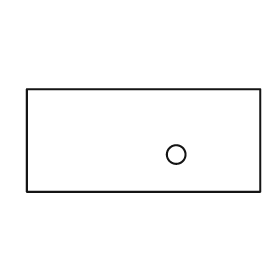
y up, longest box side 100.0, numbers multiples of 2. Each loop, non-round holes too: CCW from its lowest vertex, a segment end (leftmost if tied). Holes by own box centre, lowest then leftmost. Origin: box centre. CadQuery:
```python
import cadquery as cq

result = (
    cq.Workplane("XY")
    .moveTo(-50.0, -22.0)
    .lineTo(50.0, -22.0)
    .lineTo(50.0, 22.0)
    .lineTo(-50.0, 22.0)
    .close()
    .moveTo(14.0, -6.0)
    .circle(4.0)
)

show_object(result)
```